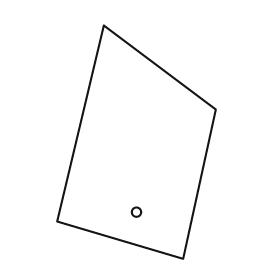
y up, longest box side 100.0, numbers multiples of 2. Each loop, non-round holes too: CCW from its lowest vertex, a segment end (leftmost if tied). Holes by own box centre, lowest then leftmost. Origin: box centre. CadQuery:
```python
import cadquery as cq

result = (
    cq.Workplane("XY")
    .moveTo(20.0, -50.0)
    .lineTo(34.0, 14.0)
    .lineTo(-14.0, 50.0)
    .lineTo(-34.0, -34.0)
    .close()
    .moveTo(0.0, -30.0)
    .circle(2.0)
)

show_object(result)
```